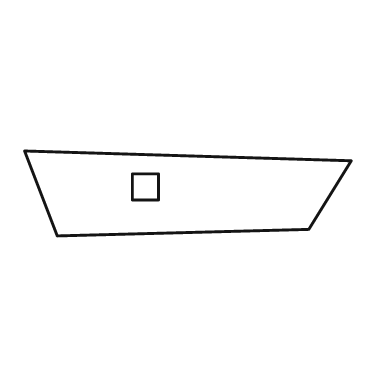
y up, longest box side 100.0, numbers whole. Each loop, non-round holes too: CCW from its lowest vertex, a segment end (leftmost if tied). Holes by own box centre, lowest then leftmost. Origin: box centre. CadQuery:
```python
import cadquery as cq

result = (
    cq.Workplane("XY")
    .moveTo(-40.0, -13.0)
    .lineTo(37.0, -11.0)
    .lineTo(50.0, 10.0)
    .lineTo(-50.0, 13.0)
    .close()
    .moveTo(-17.0, -2.0)
    .lineTo(-9.0, -2.0)
    .lineTo(-9.0, 6.0)
    .lineTo(-17.0, 6.0)
    .close()
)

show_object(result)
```